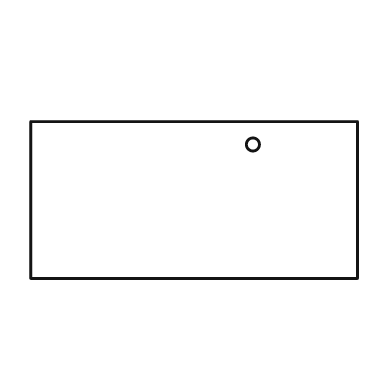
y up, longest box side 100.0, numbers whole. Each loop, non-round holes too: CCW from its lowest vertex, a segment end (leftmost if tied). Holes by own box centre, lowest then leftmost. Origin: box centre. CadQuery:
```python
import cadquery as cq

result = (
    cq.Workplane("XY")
    .moveTo(-50.0, -24.0)
    .lineTo(50.0, -24.0)
    .lineTo(50.0, 24.0)
    .lineTo(-50.0, 24.0)
    .close()
    .moveTo(18.0, 17.0)
    .circle(2.0)
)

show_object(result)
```